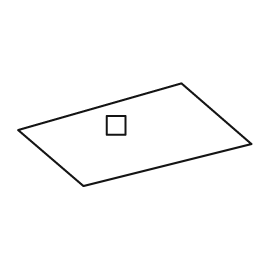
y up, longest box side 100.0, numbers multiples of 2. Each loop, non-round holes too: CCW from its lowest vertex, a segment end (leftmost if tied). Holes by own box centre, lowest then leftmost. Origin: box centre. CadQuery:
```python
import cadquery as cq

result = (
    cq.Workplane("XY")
    .moveTo(-22.0, -22.0)
    .lineTo(50.0, -4.0)
    .lineTo(20.0, 22.0)
    .lineTo(-50.0, 2.0)
    .close()
    .moveTo(-12.0, 0.0)
    .lineTo(-4.0, 0.0)
    .lineTo(-4.0, 8.0)
    .lineTo(-12.0, 8.0)
    .close()
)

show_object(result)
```